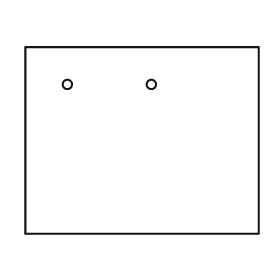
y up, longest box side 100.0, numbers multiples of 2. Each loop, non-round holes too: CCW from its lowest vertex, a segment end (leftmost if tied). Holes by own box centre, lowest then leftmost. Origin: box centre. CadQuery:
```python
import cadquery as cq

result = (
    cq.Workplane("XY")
    .moveTo(-50.0, -40.0)
    .lineTo(50.0, -40.0)
    .lineTo(50.0, 40.0)
    .lineTo(-50.0, 40.0)
    .close()
    .moveTo(-32.0, 24.0)
    .circle(2.0)
    .moveTo(4.0, 24.0)
    .circle(2.0)
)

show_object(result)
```